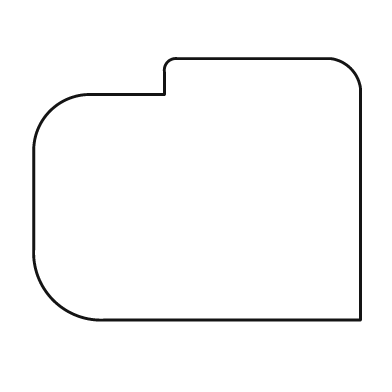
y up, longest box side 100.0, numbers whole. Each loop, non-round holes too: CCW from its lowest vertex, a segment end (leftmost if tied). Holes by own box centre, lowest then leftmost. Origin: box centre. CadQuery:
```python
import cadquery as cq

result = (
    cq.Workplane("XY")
    .moveTo(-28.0, -40.0)
    .lineTo(50.0, -40.0)
    .lineTo(50.0, 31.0)
    .threePointArc((47.0, 37.0), (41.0, 40.0))
    .lineTo(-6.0, 40.0)
    .threePointArc((-9.0, 39.0), (-10.0, 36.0))
    .lineTo(-10.0, 29.0)
    .lineTo(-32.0, 29.0)
    .threePointArc((-45.0, 24.0), (-50.0, 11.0))
    .lineTo(-50.0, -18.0)
    .threePointArc((-44.0, -34.0), (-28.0, -40.0))
    .close()
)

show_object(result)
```